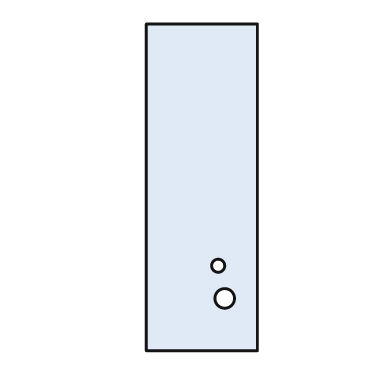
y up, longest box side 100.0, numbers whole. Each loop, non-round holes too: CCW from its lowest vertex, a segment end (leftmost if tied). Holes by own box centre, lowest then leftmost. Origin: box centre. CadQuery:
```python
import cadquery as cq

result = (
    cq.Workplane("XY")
    .moveTo(-17.0, -50.0)
    .lineTo(17.0, -50.0)
    .lineTo(17.0, 50.0)
    .lineTo(-17.0, 50.0)
    .close()
    .moveTo(7.0, -34.0)
    .circle(3.0)
    .moveTo(5.0, -24.0)
    .circle(2.0)
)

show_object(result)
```